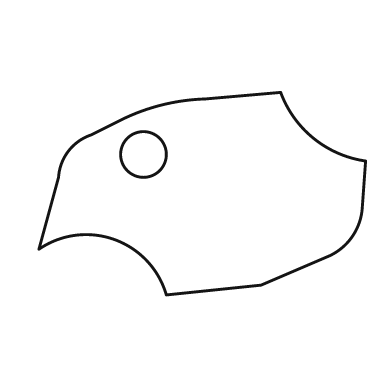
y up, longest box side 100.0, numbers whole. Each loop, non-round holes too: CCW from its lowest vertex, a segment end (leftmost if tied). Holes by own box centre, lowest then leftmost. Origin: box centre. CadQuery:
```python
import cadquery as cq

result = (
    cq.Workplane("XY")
    .moveTo(-11.0, -31.0)
    .lineTo(18.0, -28.0)
    .lineTo(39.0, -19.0)
    .threePointArc((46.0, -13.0), (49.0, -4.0))
    .lineTo(50.0, 10.0)
    .threePointArc((34.0, 17.0), (24.0, 31.0))
    .lineTo(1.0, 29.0)
    .threePointArc((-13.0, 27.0), (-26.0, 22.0))
    .lineTo(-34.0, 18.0)
    .threePointArc((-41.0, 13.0), (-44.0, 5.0))
    .lineTo(-50.0, -17.0)
    .threePointArc((-27.0, -14.0), (-11.0, -31.0))
    .close()
    .moveTo(-18.0, 12.0)
    .circle(7.0)
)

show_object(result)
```